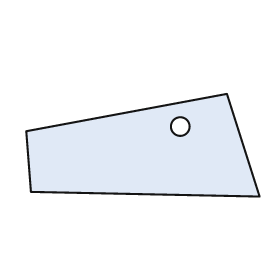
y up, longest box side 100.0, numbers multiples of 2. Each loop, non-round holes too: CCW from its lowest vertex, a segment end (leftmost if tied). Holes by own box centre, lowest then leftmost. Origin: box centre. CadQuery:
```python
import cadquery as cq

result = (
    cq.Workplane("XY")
    .moveTo(50.0, -22.0)
    .lineTo(36.0, 22.0)
    .lineTo(-50.0, 6.0)
    .lineTo(-48.0, -20.0)
    .close()
    .moveTo(16.0, 8.0)
    .circle(4.0)
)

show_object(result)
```